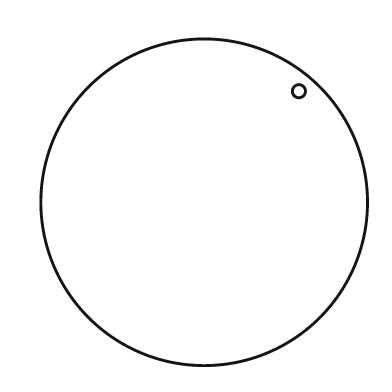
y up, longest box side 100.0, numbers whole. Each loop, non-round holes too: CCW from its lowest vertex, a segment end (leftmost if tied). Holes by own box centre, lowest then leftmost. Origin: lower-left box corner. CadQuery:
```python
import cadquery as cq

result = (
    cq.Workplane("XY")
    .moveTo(50.0, 50.0)
    .circle(50.0)
    .moveTo(79.0, 84.0)
    .circle(2.0)
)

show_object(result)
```